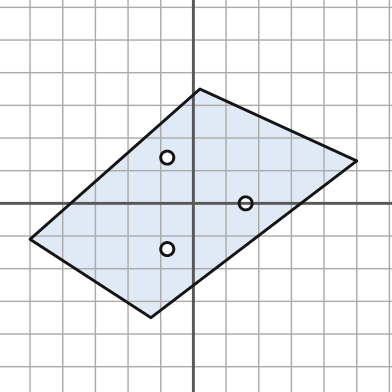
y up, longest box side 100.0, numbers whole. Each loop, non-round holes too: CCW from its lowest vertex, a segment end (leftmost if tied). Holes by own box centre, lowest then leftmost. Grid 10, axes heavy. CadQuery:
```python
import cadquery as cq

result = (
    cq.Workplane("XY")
    .moveTo(-13.0, -35.0)
    .lineTo(50.0, 13.0)
    .lineTo(2.0, 35.0)
    .lineTo(-50.0, -11.0)
    .close()
    .moveTo(-8.0, -14.0)
    .circle(2.0)
    .moveTo(16.0, 0.0)
    .circle(2.0)
    .moveTo(-8.0, 14.0)
    .circle(2.0)
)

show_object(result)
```